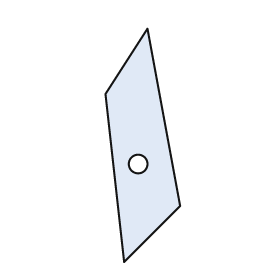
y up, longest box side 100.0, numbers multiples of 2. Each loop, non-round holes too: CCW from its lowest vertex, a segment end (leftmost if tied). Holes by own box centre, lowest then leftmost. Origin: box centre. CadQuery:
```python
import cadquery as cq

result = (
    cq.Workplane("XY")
    .moveTo(-8.0, -50.0)
    .lineTo(16.0, -26.0)
    .lineTo(2.0, 50.0)
    .lineTo(-16.0, 22.0)
    .close()
    .moveTo(-2.0, -8.0)
    .circle(4.0)
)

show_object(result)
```